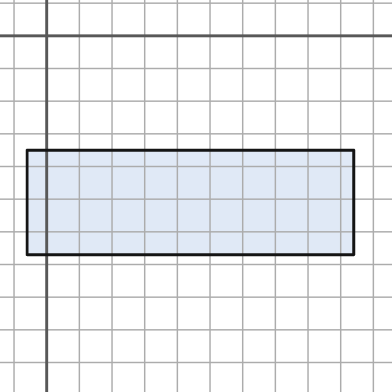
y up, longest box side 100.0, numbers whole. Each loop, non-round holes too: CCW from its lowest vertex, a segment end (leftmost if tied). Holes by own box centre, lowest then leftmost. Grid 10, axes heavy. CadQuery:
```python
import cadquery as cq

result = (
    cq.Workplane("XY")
    .moveTo(-6.0, -67.0)
    .lineTo(94.0, -67.0)
    .lineTo(94.0, -35.0)
    .lineTo(-6.0, -35.0)
    .close()
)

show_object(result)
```